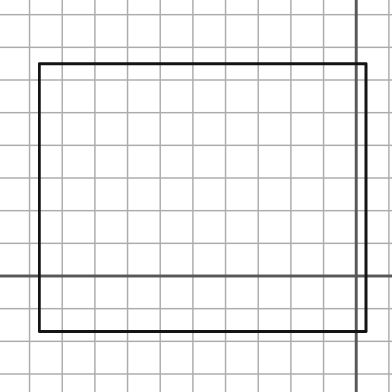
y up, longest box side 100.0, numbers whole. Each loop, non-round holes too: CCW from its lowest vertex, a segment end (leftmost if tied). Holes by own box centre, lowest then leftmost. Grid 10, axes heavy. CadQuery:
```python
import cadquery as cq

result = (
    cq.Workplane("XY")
    .moveTo(-97.0, -17.0)
    .lineTo(3.0, -17.0)
    .lineTo(3.0, 65.0)
    .lineTo(-97.0, 65.0)
    .close()
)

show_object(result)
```